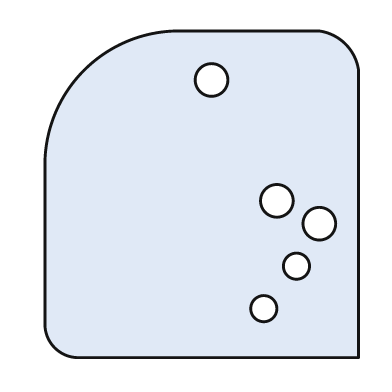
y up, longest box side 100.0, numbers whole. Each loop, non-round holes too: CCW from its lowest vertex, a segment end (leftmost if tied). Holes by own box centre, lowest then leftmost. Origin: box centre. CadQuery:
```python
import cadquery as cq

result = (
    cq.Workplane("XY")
    .moveTo(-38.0, -50.0)
    .lineTo(48.0, -50.0)
    .lineTo(48.0, 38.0)
    .threePointArc((44.0, 46.0), (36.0, 50.0))
    .lineTo(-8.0, 50.0)
    .threePointArc((-36.0, 38.0), (-48.0, 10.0))
    .lineTo(-48.0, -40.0)
    .threePointArc((-45.0, -47.0), (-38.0, -50.0))
    .close()
    .moveTo(19.0, -35.0)
    .circle(4.0)
    .moveTo(29.0, -22.0)
    .circle(4.0)
    .moveTo(36.0, -9.0)
    .circle(5.0)
    .moveTo(23.0, -2.0)
    .circle(5.0)
    .moveTo(3.0, 35.0)
    .circle(5.0)
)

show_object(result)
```